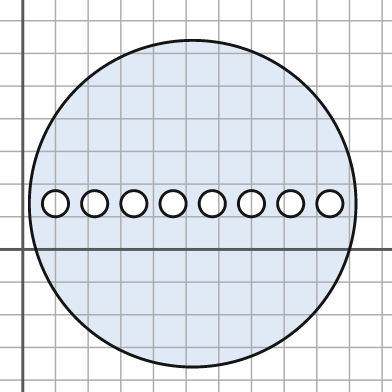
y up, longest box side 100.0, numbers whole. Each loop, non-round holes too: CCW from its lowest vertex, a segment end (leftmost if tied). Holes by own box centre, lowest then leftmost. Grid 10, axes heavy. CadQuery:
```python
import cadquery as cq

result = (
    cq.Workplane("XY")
    .moveTo(52.0, 14.0)
    .circle(50.0)
    .moveTo(10.0, 14.0)
    .circle(4.0)
    .moveTo(22.0, 14.0)
    .circle(4.0)
    .moveTo(34.0, 14.0)
    .circle(4.0)
    .moveTo(46.0, 14.0)
    .circle(4.0)
    .moveTo(58.0, 14.0)
    .circle(4.0)
    .moveTo(70.0, 14.0)
    .circle(4.0)
    .moveTo(82.0, 14.0)
    .circle(4.0)
    .moveTo(94.0, 14.0)
    .circle(4.0)
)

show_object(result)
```